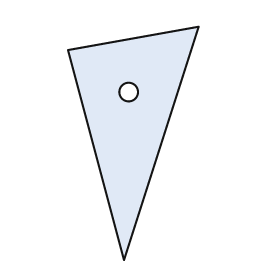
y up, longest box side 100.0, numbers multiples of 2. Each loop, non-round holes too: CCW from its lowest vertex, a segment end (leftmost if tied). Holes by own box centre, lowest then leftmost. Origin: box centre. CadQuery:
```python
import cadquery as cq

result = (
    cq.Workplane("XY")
    .moveTo(-4.0, -50.0)
    .lineTo(28.0, 50.0)
    .lineTo(-28.0, 40.0)
    .close()
    .moveTo(-2.0, 22.0)
    .circle(4.0)
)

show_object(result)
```